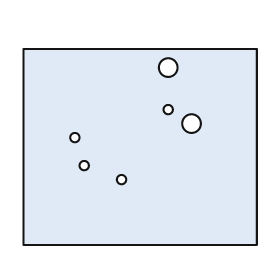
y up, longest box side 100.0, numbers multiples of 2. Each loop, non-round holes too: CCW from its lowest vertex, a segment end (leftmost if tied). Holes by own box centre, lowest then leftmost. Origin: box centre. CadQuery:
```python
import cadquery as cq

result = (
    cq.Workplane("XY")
    .moveTo(-50.0, -42.0)
    .lineTo(50.0, -42.0)
    .lineTo(50.0, 42.0)
    .lineTo(-50.0, 42.0)
    .close()
    .moveTo(-8.0, -14.0)
    .circle(2.0)
    .moveTo(-24.0, -8.0)
    .circle(2.0)
    .moveTo(-28.0, 4.0)
    .circle(2.0)
    .moveTo(22.0, 10.0)
    .circle(4.0)
    .moveTo(12.0, 16.0)
    .circle(2.0)
    .moveTo(12.0, 34.0)
    .circle(4.0)
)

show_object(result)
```